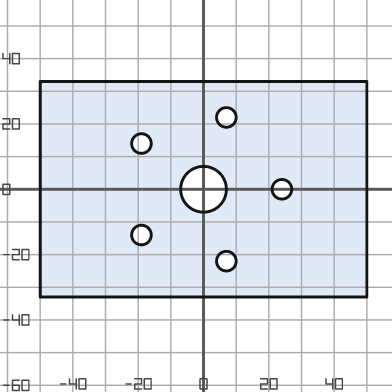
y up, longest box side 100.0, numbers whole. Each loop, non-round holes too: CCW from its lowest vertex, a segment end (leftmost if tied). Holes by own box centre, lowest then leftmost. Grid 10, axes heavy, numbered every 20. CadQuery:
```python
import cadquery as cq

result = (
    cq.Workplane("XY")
    .moveTo(-50.0, -33.0)
    .lineTo(50.0, -33.0)
    .lineTo(50.0, 33.0)
    .lineTo(-50.0, 33.0)
    .close()
    .moveTo(7.0, -22.0)
    .circle(3.0)
    .moveTo(-19.0, -14.0)
    .circle(3.0)
    .moveTo(0.0, 0.0)
    .circle(7.0)
    .moveTo(24.0, 0.0)
    .circle(3.0)
    .moveTo(-19.0, 14.0)
    .circle(3.0)
    .moveTo(7.0, 22.0)
    .circle(3.0)
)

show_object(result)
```